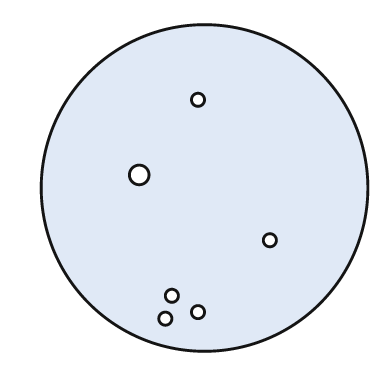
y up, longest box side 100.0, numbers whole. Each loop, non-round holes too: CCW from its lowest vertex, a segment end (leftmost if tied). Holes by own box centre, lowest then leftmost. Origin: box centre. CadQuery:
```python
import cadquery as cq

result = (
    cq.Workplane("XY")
    .moveTo(0.0, 0.0)
    .circle(50.0)
    .moveTo(-12.0, -40.0)
    .circle(2.0)
    .moveTo(-2.0, -38.0)
    .circle(2.0)
    .moveTo(-10.0, -33.0)
    .circle(2.0)
    .moveTo(20.0, -16.0)
    .circle(2.0)
    .moveTo(-20.0, 4.0)
    .circle(3.0)
    .moveTo(-2.0, 27.0)
    .circle(2.0)
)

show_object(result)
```